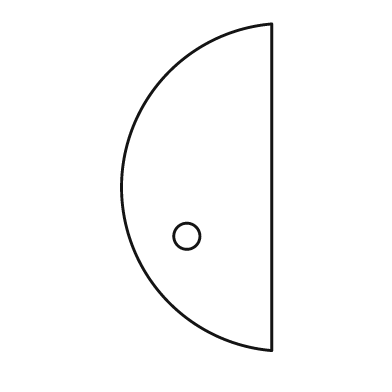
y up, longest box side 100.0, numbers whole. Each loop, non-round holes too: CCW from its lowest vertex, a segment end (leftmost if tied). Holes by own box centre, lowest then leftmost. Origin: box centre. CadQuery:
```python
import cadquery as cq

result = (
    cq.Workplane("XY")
    .moveTo(23.0, -50.0)
    .lineTo(23.0, 50.0)
    .threePointArc((-23.0, 0.0), (23.0, -50.0))
    .close()
    .moveTo(-3.0, -15.0)
    .circle(4.0)
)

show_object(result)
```